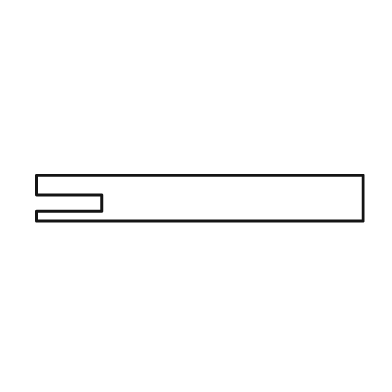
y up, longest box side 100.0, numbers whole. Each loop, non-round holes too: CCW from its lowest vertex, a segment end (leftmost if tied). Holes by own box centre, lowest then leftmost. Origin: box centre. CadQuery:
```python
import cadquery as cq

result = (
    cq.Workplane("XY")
    .moveTo(-50.0, -7.0)
    .lineTo(50.0, -7.0)
    .lineTo(50.0, 7.0)
    .lineTo(-50.0, 7.0)
    .lineTo(-50.0, 1.0)
    .lineTo(-30.0, 1.0)
    .lineTo(-30.0, -4.0)
    .lineTo(-50.0, -4.0)
    .close()
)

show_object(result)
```